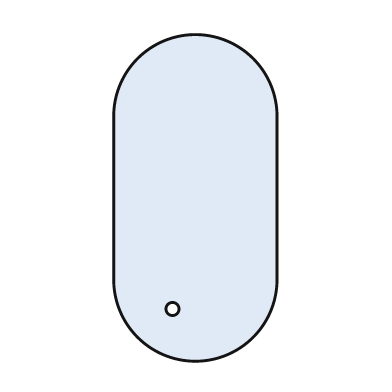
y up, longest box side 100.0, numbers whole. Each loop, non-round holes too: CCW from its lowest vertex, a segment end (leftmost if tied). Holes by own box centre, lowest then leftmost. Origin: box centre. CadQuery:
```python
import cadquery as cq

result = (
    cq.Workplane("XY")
    .moveTo(-25.0, -25.0)
    .threePointArc((0.0, -50.0), (25.0, -25.0))
    .lineTo(25.0, 25.0)
    .threePointArc((0.0, 50.0), (-25.0, 25.0))
    .close()
    .moveTo(-7.0, -34.0)
    .circle(2.0)
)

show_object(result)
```